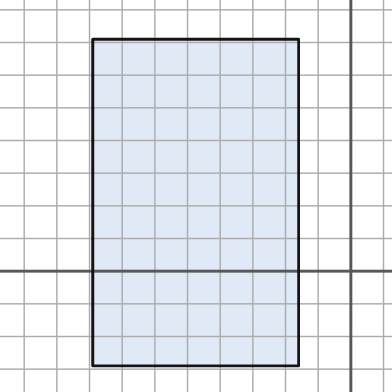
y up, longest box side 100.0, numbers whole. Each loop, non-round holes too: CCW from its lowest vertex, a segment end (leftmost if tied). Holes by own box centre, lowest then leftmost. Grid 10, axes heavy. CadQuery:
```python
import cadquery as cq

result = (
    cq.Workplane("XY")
    .moveTo(-79.0, -29.0)
    .lineTo(-16.0, -29.0)
    .lineTo(-16.0, 71.0)
    .lineTo(-79.0, 71.0)
    .close()
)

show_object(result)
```